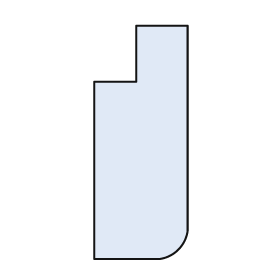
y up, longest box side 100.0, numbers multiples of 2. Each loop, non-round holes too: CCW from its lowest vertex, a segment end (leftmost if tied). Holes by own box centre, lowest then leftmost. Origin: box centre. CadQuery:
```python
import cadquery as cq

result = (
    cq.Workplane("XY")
    .moveTo(-20.0, -50.0)
    .lineTo(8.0, -50.0)
    .threePointArc((16.0, -46.0), (20.0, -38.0))
    .lineTo(20.0, 50.0)
    .lineTo(-2.0, 50.0)
    .lineTo(-2.0, 26.0)
    .lineTo(-20.0, 26.0)
    .close()
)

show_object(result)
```